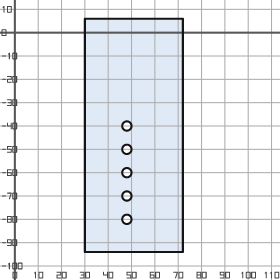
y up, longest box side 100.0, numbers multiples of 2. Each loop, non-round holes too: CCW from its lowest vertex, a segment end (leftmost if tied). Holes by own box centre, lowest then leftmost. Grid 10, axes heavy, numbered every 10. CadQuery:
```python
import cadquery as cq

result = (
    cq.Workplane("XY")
    .moveTo(30.0, -94.0)
    .lineTo(72.0, -94.0)
    .lineTo(72.0, 6.0)
    .lineTo(30.0, 6.0)
    .close()
    .moveTo(48.0, -80.0)
    .circle(2.0)
    .moveTo(48.0, -70.0)
    .circle(2.0)
    .moveTo(48.0, -60.0)
    .circle(2.0)
    .moveTo(48.0, -50.0)
    .circle(2.0)
    .moveTo(48.0, -40.0)
    .circle(2.0)
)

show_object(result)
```